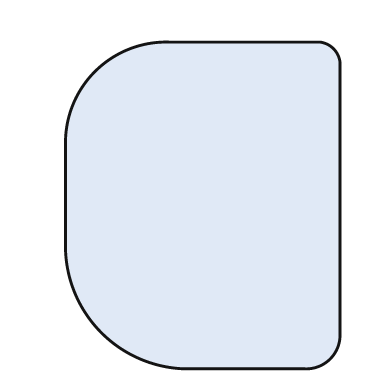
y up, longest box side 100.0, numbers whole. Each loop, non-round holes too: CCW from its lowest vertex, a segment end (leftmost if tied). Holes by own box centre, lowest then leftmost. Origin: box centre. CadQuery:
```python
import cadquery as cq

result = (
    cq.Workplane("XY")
    .moveTo(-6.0, -50.0)
    .lineTo(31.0, -50.0)
    .threePointArc((39.0, -47.0), (42.0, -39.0))
    .lineTo(42.0, 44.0)
    .threePointArc((40.0, 48.0), (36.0, 50.0))
    .lineTo(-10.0, 50.0)
    .threePointArc((-33.0, 41.0), (-42.0, 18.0))
    .lineTo(-42.0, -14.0)
    .threePointArc((-31.0, -39.0), (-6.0, -50.0))
    .close()
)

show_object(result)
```